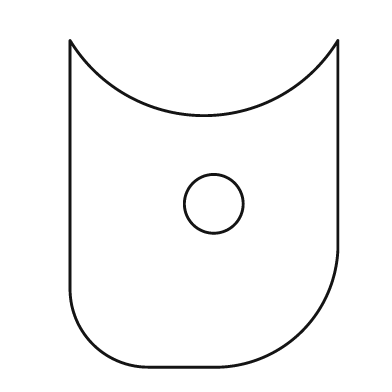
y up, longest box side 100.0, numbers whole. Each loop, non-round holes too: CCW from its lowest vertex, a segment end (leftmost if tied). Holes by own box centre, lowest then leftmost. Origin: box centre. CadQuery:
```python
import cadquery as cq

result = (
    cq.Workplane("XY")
    .moveTo(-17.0, -50.0)
    .lineTo(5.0, -50.0)
    .threePointArc((30.0, -39.0), (41.0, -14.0))
    .lineTo(41.0, 50.0)
    .threePointArc((0.0, 27.0), (-41.0, 50.0))
    .lineTo(-41.0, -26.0)
    .threePointArc((-34.0, -43.0), (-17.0, -50.0))
    .close()
    .moveTo(3.0, 0.0)
    .circle(9.0)
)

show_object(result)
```